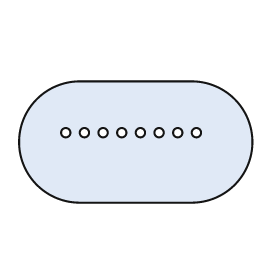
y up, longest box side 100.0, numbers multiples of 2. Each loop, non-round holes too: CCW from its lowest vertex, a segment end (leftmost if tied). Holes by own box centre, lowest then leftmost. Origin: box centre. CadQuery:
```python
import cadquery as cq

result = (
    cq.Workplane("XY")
    .moveTo(-24.0, -26.0)
    .lineTo(24.0, -26.0)
    .threePointArc((50.0, 0.0), (24.0, 26.0))
    .lineTo(-24.0, 26.0)
    .threePointArc((-50.0, 0.0), (-24.0, -26.0))
    .close()
    .moveTo(-30.0, 4.0)
    .circle(2.0)
    .moveTo(-22.0, 4.0)
    .circle(2.0)
    .moveTo(-14.0, 4.0)
    .circle(2.0)
    .moveTo(-6.0, 4.0)
    .circle(2.0)
    .moveTo(2.0, 4.0)
    .circle(2.0)
    .moveTo(10.0, 4.0)
    .circle(2.0)
    .moveTo(18.0, 4.0)
    .circle(2.0)
    .moveTo(26.0, 4.0)
    .circle(2.0)
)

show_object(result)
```